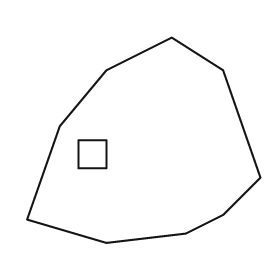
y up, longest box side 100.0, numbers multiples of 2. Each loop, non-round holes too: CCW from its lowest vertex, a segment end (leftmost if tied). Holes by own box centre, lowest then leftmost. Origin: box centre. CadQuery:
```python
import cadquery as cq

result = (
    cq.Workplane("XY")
    .moveTo(-16.0, -44.0)
    .lineTo(18.0, -40.0)
    .lineTo(34.0, -32.0)
    .lineTo(50.0, -16.0)
    .lineTo(34.0, 30.0)
    .lineTo(12.0, 44.0)
    .lineTo(-16.0, 30.0)
    .lineTo(-36.0, 6.0)
    .lineTo(-50.0, -34.0)
    .close()
    .moveTo(-28.0, -12.0)
    .lineTo(-16.0, -12.0)
    .lineTo(-16.0, 0.0)
    .lineTo(-28.0, 0.0)
    .close()
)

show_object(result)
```